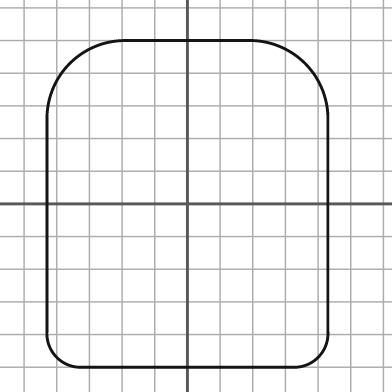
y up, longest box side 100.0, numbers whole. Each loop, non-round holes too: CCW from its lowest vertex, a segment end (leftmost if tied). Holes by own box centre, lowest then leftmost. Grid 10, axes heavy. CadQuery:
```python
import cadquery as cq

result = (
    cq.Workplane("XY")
    .moveTo(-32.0, -50.0)
    .lineTo(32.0, -50.0)
    .threePointArc((40.0, -47.0), (43.0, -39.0))
    .lineTo(43.0, 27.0)
    .threePointArc((36.0, 43.0), (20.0, 50.0))
    .lineTo(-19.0, 50.0)
    .threePointArc((-36.0, 43.0), (-43.0, 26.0))
    .lineTo(-43.0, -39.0)
    .threePointArc((-40.0, -47.0), (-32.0, -50.0))
    .close()
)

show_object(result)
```